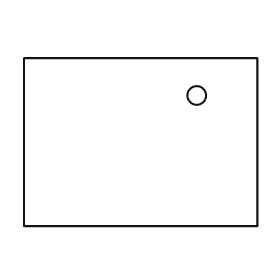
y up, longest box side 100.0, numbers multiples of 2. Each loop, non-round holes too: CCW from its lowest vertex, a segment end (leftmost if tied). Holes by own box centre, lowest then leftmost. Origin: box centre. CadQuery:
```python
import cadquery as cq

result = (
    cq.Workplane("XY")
    .moveTo(-50.0, -36.0)
    .lineTo(50.0, -36.0)
    .lineTo(50.0, 36.0)
    .lineTo(-50.0, 36.0)
    .close()
    .moveTo(24.0, 20.0)
    .circle(4.0)
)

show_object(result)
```